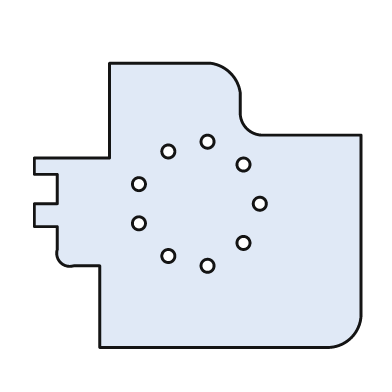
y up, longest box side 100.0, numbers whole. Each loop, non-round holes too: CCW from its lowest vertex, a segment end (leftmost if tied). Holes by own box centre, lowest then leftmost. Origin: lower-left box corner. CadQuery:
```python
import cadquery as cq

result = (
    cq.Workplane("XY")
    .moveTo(20.0, 0.0)
    .lineTo(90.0, 0.0)
    .threePointArc((97.0, 3.0), (100.0, 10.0))
    .lineTo(100.0, 65.0)
    .lineTo(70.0, 65.0)
    .threePointArc((65.0, 67.0), (63.0, 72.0))
    .lineTo(63.0, 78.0)
    .threePointArc((60.0, 84.0), (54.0, 87.0))
    .lineTo(23.0, 87.0)
    .lineTo(23.0, 58.0)
    .lineTo(0.0, 58.0)
    .lineTo(0.0, 53.0)
    .lineTo(7.0, 53.0)
    .lineTo(7.0, 44.0)
    .lineTo(0.0, 44.0)
    .lineTo(0.0, 37.0)
    .lineTo(7.0, 37.0)
    .lineTo(7.0, 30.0)
    .threePointArc((8.0, 26.0), (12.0, 25.0))
    .lineTo(20.0, 25.0)
    .close()
    .moveTo(53.0, 25.0)
    .circle(2.0)
    .moveTo(41.0, 28.0)
    .circle(2.0)
    .moveTo(64.0, 32.0)
    .circle(2.0)
    .moveTo(32.0, 38.0)
    .circle(2.0)
    .moveTo(69.0, 44.0)
    .circle(2.0)
    .moveTo(32.0, 50.0)
    .circle(2.0)
    .moveTo(64.0, 56.0)
    .circle(2.0)
    .moveTo(41.0, 60.0)
    .circle(2.0)
    .moveTo(53.0, 63.0)
    .circle(2.0)
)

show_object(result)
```